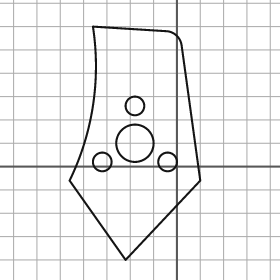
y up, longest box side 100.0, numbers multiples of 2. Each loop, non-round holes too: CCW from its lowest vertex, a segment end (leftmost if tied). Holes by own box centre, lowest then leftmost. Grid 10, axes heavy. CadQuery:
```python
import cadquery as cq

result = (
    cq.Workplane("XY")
    .moveTo(-22.0, -40.0)
    .lineTo(10.0, -6.0)
    .lineTo(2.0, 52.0)
    .threePointArc((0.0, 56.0), (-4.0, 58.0))
    .lineTo(-36.0, 60.0)
    .threePointArc((-36.0, 26.0), (-46.0, -6.0))
    .close()
    .moveTo(-32.0, 2.0)
    .circle(4.0)
    .moveTo(-4.0, 2.0)
    .circle(4.0)
    .moveTo(-18.0, 10.0)
    .circle(8.0)
    .moveTo(-18.0, 26.0)
    .circle(4.0)
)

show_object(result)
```